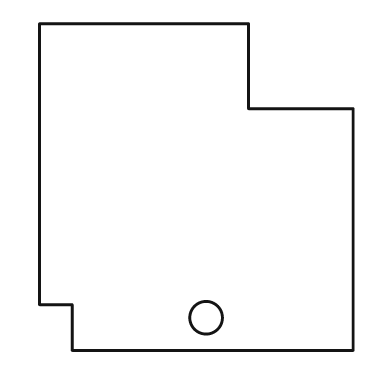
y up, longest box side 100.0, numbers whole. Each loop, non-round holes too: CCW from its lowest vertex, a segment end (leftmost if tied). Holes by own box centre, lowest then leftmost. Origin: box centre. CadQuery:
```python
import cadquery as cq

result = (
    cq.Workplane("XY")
    .moveTo(-38.0, -50.0)
    .lineTo(48.0, -50.0)
    .lineTo(48.0, 24.0)
    .lineTo(16.0, 24.0)
    .lineTo(16.0, 50.0)
    .lineTo(-48.0, 50.0)
    .lineTo(-48.0, -36.0)
    .lineTo(-38.0, -36.0)
    .close()
    .moveTo(3.0, -40.0)
    .circle(5.0)
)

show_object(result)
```